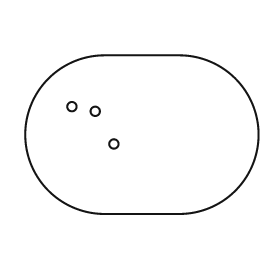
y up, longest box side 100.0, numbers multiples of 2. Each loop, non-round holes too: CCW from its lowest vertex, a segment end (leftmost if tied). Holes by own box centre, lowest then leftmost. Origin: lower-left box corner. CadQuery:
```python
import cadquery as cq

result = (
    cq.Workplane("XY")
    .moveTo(34.0, 0.0)
    .lineTo(66.0, 0.0)
    .threePointArc((100.0, 34.0), (66.0, 68.0))
    .lineTo(34.0, 68.0)
    .threePointArc((0.0, 34.0), (34.0, 0.0))
    .close()
    .moveTo(38.0, 30.0)
    .circle(2.0)
    .moveTo(30.0, 44.0)
    .circle(2.0)
    .moveTo(20.0, 46.0)
    .circle(2.0)
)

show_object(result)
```